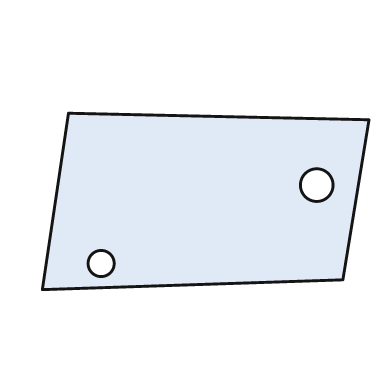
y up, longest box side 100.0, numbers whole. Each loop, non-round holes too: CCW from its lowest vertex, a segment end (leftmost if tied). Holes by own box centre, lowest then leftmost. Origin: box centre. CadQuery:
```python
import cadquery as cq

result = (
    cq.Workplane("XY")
    .moveTo(-50.0, -27.0)
    .lineTo(42.0, -24.0)
    .lineTo(50.0, 25.0)
    .lineTo(-42.0, 27.0)
    .close()
    .moveTo(-32.0, -19.0)
    .circle(4.0)
    .moveTo(34.0, 5.0)
    .circle(5.0)
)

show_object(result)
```